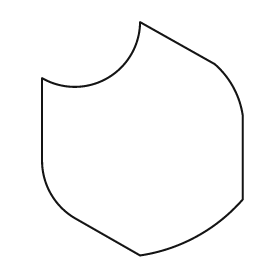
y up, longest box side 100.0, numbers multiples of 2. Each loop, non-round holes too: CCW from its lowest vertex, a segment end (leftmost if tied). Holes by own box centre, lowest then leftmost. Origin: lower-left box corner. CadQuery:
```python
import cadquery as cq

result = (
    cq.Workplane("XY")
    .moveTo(42.0, 0.0)
    .threePointArc((66.0, 8.0), (86.0, 24.0))
    .lineTo(86.0, 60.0)
    .threePointArc((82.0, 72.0), (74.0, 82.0))
    .lineTo(42.0, 100.0)
    .threePointArc((28.0, 76.0), (0.0, 76.0))
    .lineTo(0.0, 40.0)
    .threePointArc((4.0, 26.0), (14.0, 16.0))
    .close()
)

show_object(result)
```